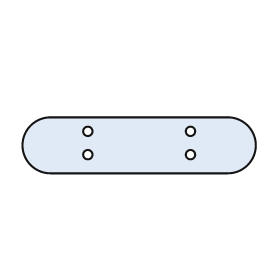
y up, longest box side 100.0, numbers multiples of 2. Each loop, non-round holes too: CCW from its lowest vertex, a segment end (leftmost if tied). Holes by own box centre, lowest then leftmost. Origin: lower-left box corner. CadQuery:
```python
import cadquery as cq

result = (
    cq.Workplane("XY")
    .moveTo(12.0, 0.0)
    .lineTo(88.0, 0.0)
    .threePointArc((100.0, 12.0), (88.0, 24.0))
    .lineTo(12.0, 24.0)
    .threePointArc((0.0, 12.0), (12.0, 0.0))
    .close()
    .moveTo(28.0, 8.0)
    .circle(2.0)
    .moveTo(72.0, 8.0)
    .circle(2.0)
    .moveTo(28.0, 18.0)
    .circle(2.0)
    .moveTo(72.0, 18.0)
    .circle(2.0)
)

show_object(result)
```